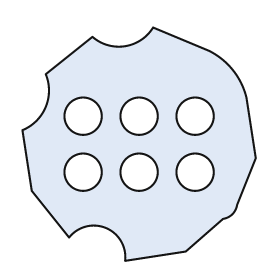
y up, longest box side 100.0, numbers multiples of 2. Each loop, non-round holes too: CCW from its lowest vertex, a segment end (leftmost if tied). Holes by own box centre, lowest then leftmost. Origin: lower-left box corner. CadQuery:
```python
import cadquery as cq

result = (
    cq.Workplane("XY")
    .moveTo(44.0, 0.0)
    .lineTo(70.0, 4.0)
    .lineTo(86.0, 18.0)
    .threePointArc((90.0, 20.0), (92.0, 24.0))
    .lineTo(100.0, 44.0)
    .lineTo(96.0, 70.0)
    .threePointArc((90.0, 82.0), (80.0, 90.0))
    .lineTo(56.0, 100.0)
    .threePointArc((44.0, 92.0), (30.0, 96.0))
    .lineTo(10.0, 80.0)
    .threePointArc((10.0, 66.0), (0.0, 56.0))
    .lineTo(4.0, 30.0)
    .lineTo(20.0, 10.0)
    .threePointArc((36.0, 14.0), (44.0, 0.0))
    .close()
    .moveTo(26.0, 38.0)
    .circle(8.0)
    .moveTo(50.0, 38.0)
    .circle(8.0)
    .moveTo(74.0, 38.0)
    .circle(8.0)
    .moveTo(26.0, 62.0)
    .circle(8.0)
    .moveTo(50.0, 62.0)
    .circle(8.0)
    .moveTo(74.0, 62.0)
    .circle(8.0)
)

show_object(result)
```